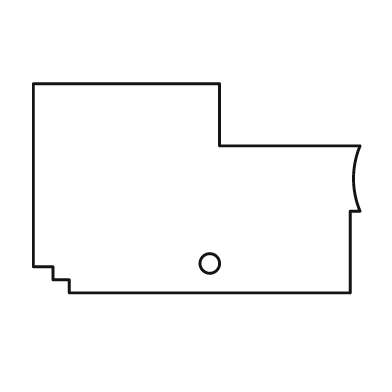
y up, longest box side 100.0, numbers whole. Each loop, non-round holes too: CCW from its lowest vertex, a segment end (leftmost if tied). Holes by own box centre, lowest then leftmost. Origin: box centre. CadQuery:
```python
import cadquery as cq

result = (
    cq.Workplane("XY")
    .moveTo(-39.0, -32.0)
    .lineTo(47.0, -32.0)
    .lineTo(47.0, -7.0)
    .lineTo(50.0, -7.0)
    .threePointArc((48.0, 3.0), (50.0, 13.0))
    .lineTo(7.0, 13.0)
    .lineTo(7.0, 32.0)
    .lineTo(-50.0, 32.0)
    .lineTo(-50.0, -24.0)
    .lineTo(-44.0, -24.0)
    .lineTo(-44.0, -28.0)
    .lineTo(-39.0, -28.0)
    .close()
    .moveTo(4.0, -23.0)
    .circle(3.0)
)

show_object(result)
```